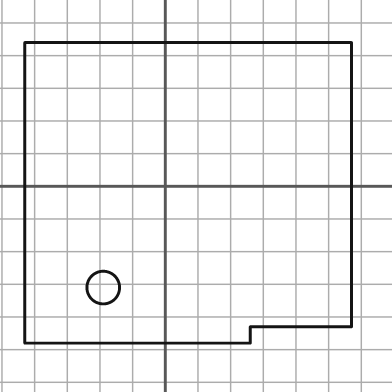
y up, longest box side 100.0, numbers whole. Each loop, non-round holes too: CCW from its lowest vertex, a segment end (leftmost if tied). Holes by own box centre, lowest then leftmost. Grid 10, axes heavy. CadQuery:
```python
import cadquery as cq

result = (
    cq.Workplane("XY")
    .moveTo(-43.0, -48.0)
    .lineTo(26.0, -48.0)
    .lineTo(26.0, -43.0)
    .lineTo(57.0, -43.0)
    .lineTo(57.0, 44.0)
    .lineTo(-43.0, 44.0)
    .close()
    .moveTo(-19.0, -31.0)
    .circle(5.0)
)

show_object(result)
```